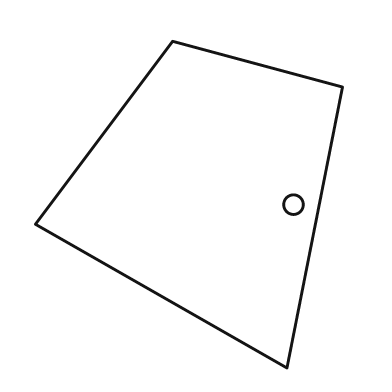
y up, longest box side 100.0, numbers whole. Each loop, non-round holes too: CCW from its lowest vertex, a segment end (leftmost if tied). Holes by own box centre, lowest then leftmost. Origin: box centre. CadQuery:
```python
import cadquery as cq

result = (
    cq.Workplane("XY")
    .moveTo(30.0, -50.0)
    .lineTo(47.0, 36.0)
    .lineTo(-5.0, 50.0)
    .lineTo(-47.0, -6.0)
    .close()
    .moveTo(32.0, 0.0)
    .circle(3.0)
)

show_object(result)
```